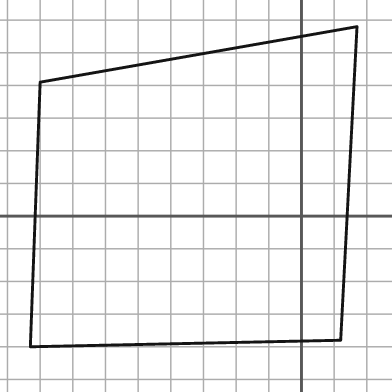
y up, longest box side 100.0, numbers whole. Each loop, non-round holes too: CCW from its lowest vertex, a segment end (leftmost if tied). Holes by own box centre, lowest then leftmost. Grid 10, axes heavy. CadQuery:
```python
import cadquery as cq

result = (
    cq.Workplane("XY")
    .moveTo(-83.0, -40.0)
    .lineTo(12.0, -38.0)
    .lineTo(17.0, 58.0)
    .lineTo(-80.0, 41.0)
    .close()
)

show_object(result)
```